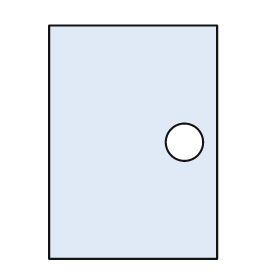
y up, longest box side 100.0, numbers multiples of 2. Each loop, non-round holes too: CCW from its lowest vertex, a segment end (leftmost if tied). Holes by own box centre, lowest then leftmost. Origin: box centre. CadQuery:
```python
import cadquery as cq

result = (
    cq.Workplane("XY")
    .moveTo(-36.0, -50.0)
    .lineTo(36.0, -50.0)
    .lineTo(36.0, 50.0)
    .lineTo(-36.0, 50.0)
    .close()
    .moveTo(22.0, 0.0)
    .circle(8.0)
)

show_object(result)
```